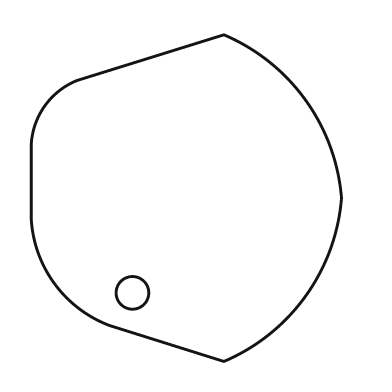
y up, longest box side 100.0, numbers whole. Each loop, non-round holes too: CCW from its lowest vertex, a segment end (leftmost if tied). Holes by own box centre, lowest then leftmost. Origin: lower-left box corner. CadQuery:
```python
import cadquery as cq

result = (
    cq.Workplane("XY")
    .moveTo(59.0, 0.0)
    .threePointArc((84.0, 20.0), (95.0, 50.0))
    .threePointArc((84.0, 80.0), (59.0, 100.0))
    .lineTo(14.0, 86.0)
    .threePointArc((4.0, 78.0), (0.0, 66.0))
    .lineTo(0.0, 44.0)
    .threePointArc((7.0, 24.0), (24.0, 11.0))
    .close()
    .moveTo(31.0, 21.0)
    .circle(5.0)
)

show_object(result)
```